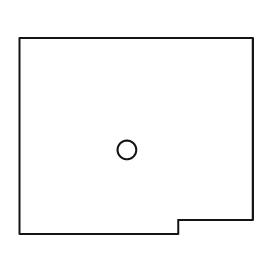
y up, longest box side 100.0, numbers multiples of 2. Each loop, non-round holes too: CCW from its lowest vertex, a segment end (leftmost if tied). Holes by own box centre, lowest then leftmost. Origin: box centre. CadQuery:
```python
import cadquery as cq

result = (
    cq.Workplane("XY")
    .moveTo(-50.0, -42.0)
    .lineTo(18.0, -42.0)
    .lineTo(18.0, -36.0)
    .lineTo(50.0, -36.0)
    .lineTo(50.0, 42.0)
    .lineTo(-50.0, 42.0)
    .close()
    .moveTo(-4.0, -6.0)
    .circle(4.0)
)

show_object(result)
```